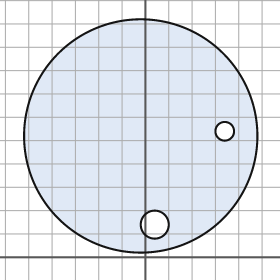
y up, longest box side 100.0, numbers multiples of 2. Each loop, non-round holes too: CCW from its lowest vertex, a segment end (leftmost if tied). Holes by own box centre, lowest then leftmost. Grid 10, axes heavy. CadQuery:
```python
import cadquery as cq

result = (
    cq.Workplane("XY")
    .moveTo(-2.0, 52.0)
    .circle(50.0)
    .moveTo(4.0, 14.0)
    .circle(6.0)
    .moveTo(34.0, 54.0)
    .circle(4.0)
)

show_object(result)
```